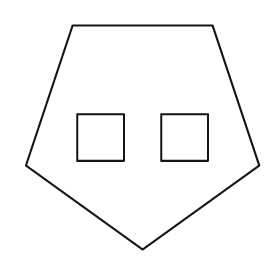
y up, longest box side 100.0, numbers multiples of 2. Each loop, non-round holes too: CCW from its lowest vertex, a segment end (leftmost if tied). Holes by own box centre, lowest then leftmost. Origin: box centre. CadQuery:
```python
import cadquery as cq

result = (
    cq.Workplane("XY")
    .moveTo(0.0, -48.0)
    .lineTo(50.0, -12.0)
    .lineTo(30.0, 48.0)
    .lineTo(-30.0, 48.0)
    .lineTo(-50.0, -12.0)
    .close()
    .moveTo(-28.0, -10.0)
    .lineTo(-8.0, -10.0)
    .lineTo(-8.0, 10.0)
    .lineTo(-28.0, 10.0)
    .close()
    .moveTo(8.0, -10.0)
    .lineTo(28.0, -10.0)
    .lineTo(28.0, 10.0)
    .lineTo(8.0, 10.0)
    .close()
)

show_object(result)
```